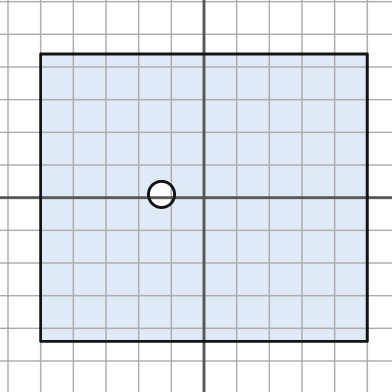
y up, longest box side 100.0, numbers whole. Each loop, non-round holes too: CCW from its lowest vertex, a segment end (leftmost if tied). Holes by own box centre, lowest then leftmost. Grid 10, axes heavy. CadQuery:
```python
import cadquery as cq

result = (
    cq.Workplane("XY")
    .moveTo(-50.0, -44.0)
    .lineTo(50.0, -44.0)
    .lineTo(50.0, 44.0)
    .lineTo(-50.0, 44.0)
    .close()
    .moveTo(-13.0, 1.0)
    .circle(4.0)
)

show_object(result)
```